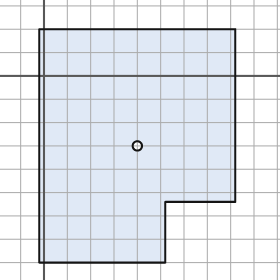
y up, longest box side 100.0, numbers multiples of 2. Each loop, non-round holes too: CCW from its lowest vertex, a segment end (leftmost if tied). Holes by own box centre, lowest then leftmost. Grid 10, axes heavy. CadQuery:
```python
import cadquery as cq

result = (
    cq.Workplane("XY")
    .moveTo(-2.0, -80.0)
    .lineTo(52.0, -80.0)
    .lineTo(52.0, -54.0)
    .lineTo(82.0, -54.0)
    .lineTo(82.0, 20.0)
    .lineTo(-2.0, 20.0)
    .close()
    .moveTo(40.0, -30.0)
    .circle(2.0)
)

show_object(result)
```